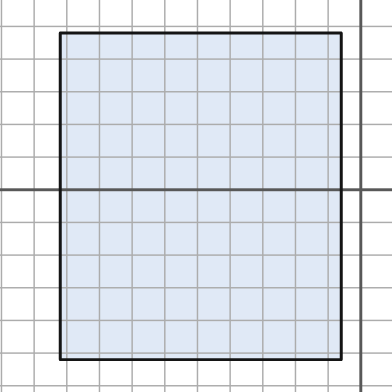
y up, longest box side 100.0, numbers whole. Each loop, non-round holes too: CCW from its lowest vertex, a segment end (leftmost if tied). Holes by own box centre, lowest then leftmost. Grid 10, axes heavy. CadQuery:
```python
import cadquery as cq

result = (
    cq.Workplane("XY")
    .moveTo(-92.0, -52.0)
    .lineTo(-6.0, -52.0)
    .lineTo(-6.0, 48.0)
    .lineTo(-92.0, 48.0)
    .close()
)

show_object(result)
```